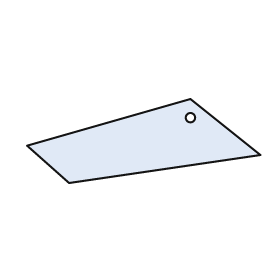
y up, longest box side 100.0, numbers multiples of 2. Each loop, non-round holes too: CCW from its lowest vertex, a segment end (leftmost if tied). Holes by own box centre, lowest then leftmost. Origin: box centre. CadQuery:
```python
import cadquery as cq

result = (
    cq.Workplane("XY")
    .moveTo(-32.0, -18.0)
    .lineTo(50.0, -6.0)
    .lineTo(20.0, 18.0)
    .lineTo(-50.0, -2.0)
    .close()
    .moveTo(20.0, 10.0)
    .circle(2.0)
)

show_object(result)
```